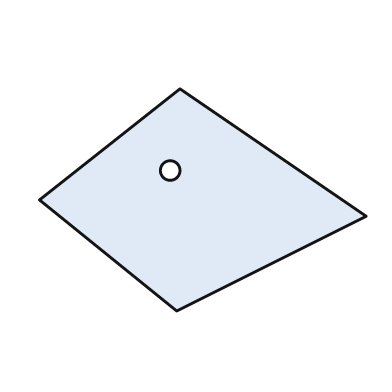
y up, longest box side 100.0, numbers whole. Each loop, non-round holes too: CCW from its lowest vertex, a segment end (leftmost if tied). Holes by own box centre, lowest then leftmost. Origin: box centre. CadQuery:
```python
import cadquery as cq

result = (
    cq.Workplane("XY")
    .moveTo(-8.0, -34.0)
    .lineTo(50.0, -5.0)
    .lineTo(-7.0, 34.0)
    .lineTo(-50.0, 0.0)
    .close()
    .moveTo(-10.0, 9.0)
    .circle(3.0)
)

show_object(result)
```